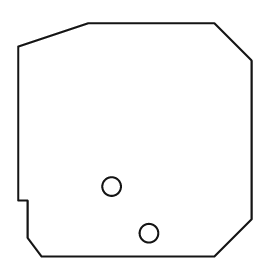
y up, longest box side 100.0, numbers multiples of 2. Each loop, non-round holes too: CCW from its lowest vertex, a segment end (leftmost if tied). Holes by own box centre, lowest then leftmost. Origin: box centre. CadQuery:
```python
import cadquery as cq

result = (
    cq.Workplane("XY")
    .moveTo(-40.0, -50.0)
    .lineTo(34.0, -50.0)
    .lineTo(50.0, -34.0)
    .lineTo(50.0, 34.0)
    .lineTo(34.0, 50.0)
    .lineTo(-20.0, 50.0)
    .lineTo(-50.0, 40.0)
    .lineTo(-50.0, -26.0)
    .lineTo(-46.0, -26.0)
    .lineTo(-46.0, -42.0)
    .close()
    .moveTo(6.0, -40.0)
    .circle(4.0)
    .moveTo(-10.0, -20.0)
    .circle(4.0)
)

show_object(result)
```